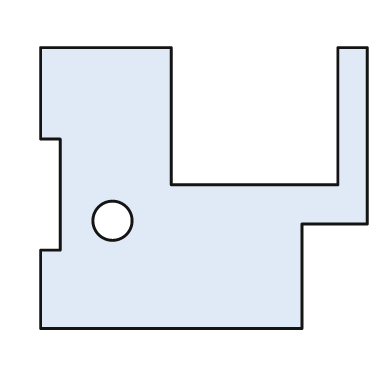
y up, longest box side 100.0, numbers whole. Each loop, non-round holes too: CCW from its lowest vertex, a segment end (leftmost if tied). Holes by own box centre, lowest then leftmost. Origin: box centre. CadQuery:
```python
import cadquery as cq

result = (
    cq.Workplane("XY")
    .moveTo(-50.0, -43.0)
    .lineTo(30.0, -43.0)
    .lineTo(30.0, -11.0)
    .lineTo(50.0, -11.0)
    .lineTo(50.0, 43.0)
    .lineTo(41.0, 43.0)
    .lineTo(41.0, 1.0)
    .lineTo(-10.0, 1.0)
    .lineTo(-10.0, 43.0)
    .lineTo(-50.0, 43.0)
    .lineTo(-50.0, 15.0)
    .lineTo(-44.0, 15.0)
    .lineTo(-44.0, -19.0)
    .lineTo(-50.0, -19.0)
    .close()
    .moveTo(-28.0, -10.0)
    .circle(6.0)
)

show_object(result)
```